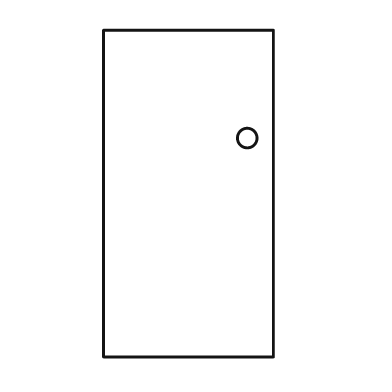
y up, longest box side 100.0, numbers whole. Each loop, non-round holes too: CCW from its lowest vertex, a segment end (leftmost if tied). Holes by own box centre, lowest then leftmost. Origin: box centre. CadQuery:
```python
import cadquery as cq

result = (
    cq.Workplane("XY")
    .moveTo(-26.0, -50.0)
    .lineTo(26.0, -50.0)
    .lineTo(26.0, 50.0)
    .lineTo(-26.0, 50.0)
    .close()
    .moveTo(18.0, 17.0)
    .circle(3.0)
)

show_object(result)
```